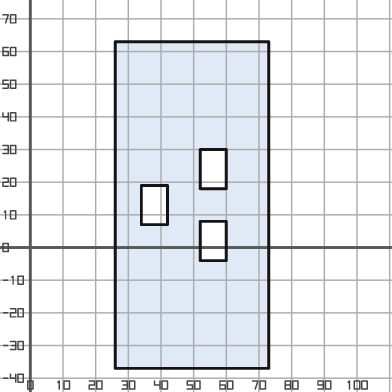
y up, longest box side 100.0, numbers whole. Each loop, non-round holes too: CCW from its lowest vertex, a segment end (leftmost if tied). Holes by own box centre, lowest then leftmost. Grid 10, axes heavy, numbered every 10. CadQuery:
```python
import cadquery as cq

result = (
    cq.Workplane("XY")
    .moveTo(26.0, -37.0)
    .lineTo(73.0, -37.0)
    .lineTo(73.0, 63.0)
    .lineTo(26.0, 63.0)
    .close()
    .moveTo(52.0, -4.0)
    .lineTo(60.0, -4.0)
    .lineTo(60.0, 8.0)
    .lineTo(52.0, 8.0)
    .close()
    .moveTo(34.0, 7.0)
    .lineTo(42.0, 7.0)
    .lineTo(42.0, 19.0)
    .lineTo(34.0, 19.0)
    .close()
    .moveTo(52.0, 18.0)
    .lineTo(60.0, 18.0)
    .lineTo(60.0, 30.0)
    .lineTo(52.0, 30.0)
    .close()
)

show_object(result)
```